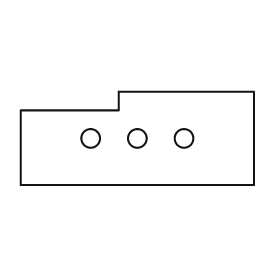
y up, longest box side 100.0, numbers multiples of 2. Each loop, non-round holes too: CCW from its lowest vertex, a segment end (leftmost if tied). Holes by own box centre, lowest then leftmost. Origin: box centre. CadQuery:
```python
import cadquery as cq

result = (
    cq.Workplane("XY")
    .moveTo(-50.0, -20.0)
    .lineTo(50.0, -20.0)
    .lineTo(50.0, 20.0)
    .lineTo(-8.0, 20.0)
    .lineTo(-8.0, 12.0)
    .lineTo(-50.0, 12.0)
    .close()
    .moveTo(-20.0, 0.0)
    .circle(4.0)
    .moveTo(0.0, 0.0)
    .circle(4.0)
    .moveTo(20.0, 0.0)
    .circle(4.0)
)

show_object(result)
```